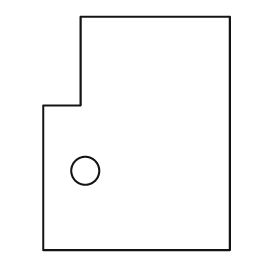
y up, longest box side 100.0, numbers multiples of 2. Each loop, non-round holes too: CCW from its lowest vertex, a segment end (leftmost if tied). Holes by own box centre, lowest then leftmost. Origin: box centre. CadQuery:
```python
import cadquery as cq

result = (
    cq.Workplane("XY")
    .moveTo(-40.0, -50.0)
    .lineTo(40.0, -50.0)
    .lineTo(40.0, 50.0)
    .lineTo(-24.0, 50.0)
    .lineTo(-24.0, 12.0)
    .lineTo(-40.0, 12.0)
    .close()
    .moveTo(-22.0, -16.0)
    .circle(6.0)
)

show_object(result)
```